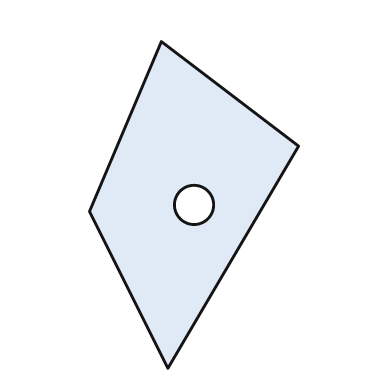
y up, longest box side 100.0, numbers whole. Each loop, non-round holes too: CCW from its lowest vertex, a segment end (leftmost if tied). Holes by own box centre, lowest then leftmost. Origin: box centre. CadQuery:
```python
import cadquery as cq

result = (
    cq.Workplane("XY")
    .moveTo(-8.0, -50.0)
    .lineTo(32.0, 18.0)
    .lineTo(-10.0, 50.0)
    .lineTo(-32.0, -2.0)
    .close()
    .moveTo(0.0, 0.0)
    .circle(6.0)
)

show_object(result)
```